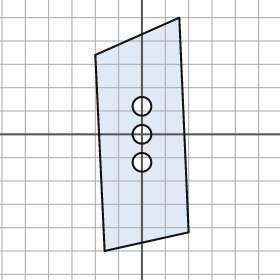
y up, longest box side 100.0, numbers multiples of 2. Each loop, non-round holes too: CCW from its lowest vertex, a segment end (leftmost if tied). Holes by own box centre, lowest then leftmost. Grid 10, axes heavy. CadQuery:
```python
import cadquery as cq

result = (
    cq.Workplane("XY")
    .moveTo(-16.0, -50.0)
    .lineTo(20.0, -42.0)
    .lineTo(16.0, 50.0)
    .lineTo(-20.0, 34.0)
    .close()
    .moveTo(0.0, -12.0)
    .circle(4.0)
    .moveTo(0.0, 0.0)
    .circle(4.0)
    .moveTo(0.0, 12.0)
    .circle(4.0)
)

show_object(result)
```